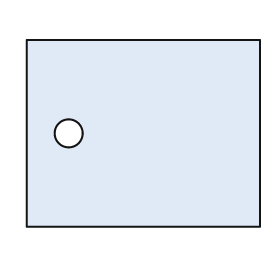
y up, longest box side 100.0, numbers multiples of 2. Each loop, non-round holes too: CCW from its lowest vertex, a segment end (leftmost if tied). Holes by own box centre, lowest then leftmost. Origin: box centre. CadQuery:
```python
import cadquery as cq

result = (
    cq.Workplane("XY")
    .moveTo(-50.0, -40.0)
    .lineTo(50.0, -40.0)
    .lineTo(50.0, 40.0)
    .lineTo(-50.0, 40.0)
    .close()
    .moveTo(-32.0, 0.0)
    .circle(6.0)
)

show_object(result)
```